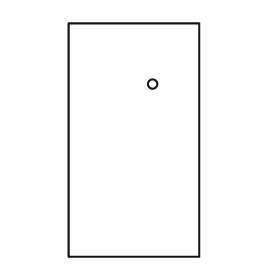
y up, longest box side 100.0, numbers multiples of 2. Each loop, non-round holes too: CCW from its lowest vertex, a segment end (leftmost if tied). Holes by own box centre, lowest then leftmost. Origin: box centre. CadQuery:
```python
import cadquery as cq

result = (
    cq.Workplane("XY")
    .moveTo(-28.0, -50.0)
    .lineTo(28.0, -50.0)
    .lineTo(28.0, 50.0)
    .lineTo(-28.0, 50.0)
    .close()
    .moveTo(8.0, 24.0)
    .circle(2.0)
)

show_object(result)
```